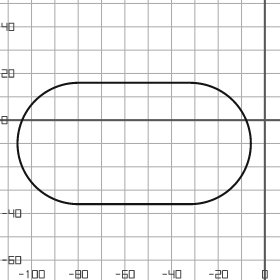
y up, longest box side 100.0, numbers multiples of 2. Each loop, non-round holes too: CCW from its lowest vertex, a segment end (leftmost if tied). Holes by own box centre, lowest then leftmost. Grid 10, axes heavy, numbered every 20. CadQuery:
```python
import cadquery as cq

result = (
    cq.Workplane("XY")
    .moveTo(-80.0, -36.0)
    .lineTo(-32.0, -36.0)
    .threePointArc((-6.0, -10.0), (-32.0, 16.0))
    .lineTo(-80.0, 16.0)
    .threePointArc((-106.0, -10.0), (-80.0, -36.0))
    .close()
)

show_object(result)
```